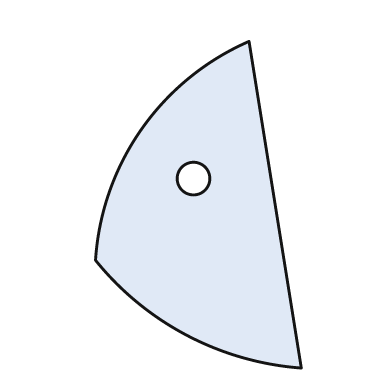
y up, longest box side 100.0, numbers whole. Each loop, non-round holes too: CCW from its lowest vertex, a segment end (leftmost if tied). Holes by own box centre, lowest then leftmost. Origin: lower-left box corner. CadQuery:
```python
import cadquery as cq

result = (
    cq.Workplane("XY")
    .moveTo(63.0, 0.0)
    .lineTo(47.0, 100.0)
    .threePointArc((14.0, 73.0), (0.0, 33.0))
    .threePointArc((28.0, 10.0), (63.0, 0.0))
    .close()
    .moveTo(30.0, 58.0)
    .circle(5.0)
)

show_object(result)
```